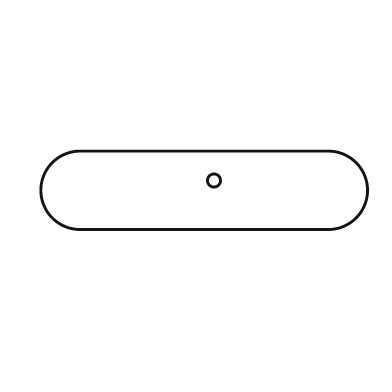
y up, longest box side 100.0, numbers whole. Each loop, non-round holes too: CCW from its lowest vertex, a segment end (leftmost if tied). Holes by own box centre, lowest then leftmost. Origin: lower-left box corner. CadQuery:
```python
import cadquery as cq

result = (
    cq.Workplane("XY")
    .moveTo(12.0, 0.0)
    .lineTo(88.0, 0.0)
    .threePointArc((100.0, 12.0), (88.0, 24.0))
    .lineTo(12.0, 24.0)
    .threePointArc((0.0, 12.0), (12.0, 0.0))
    .close()
    .moveTo(53.0, 15.0)
    .circle(2.0)
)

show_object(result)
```